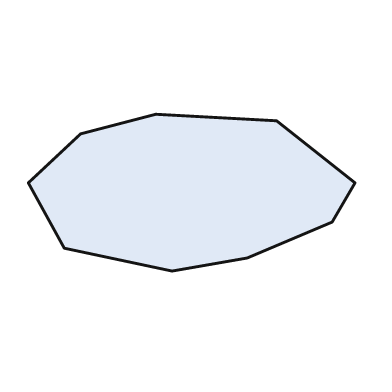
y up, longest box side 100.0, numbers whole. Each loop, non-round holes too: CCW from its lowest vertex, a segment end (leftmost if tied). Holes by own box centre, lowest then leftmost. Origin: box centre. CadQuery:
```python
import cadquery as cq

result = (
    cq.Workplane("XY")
    .moveTo(-6.0, -24.0)
    .lineTo(17.0, -20.0)
    .lineTo(43.0, -9.0)
    .lineTo(50.0, 3.0)
    .lineTo(26.0, 22.0)
    .lineTo(-11.0, 24.0)
    .lineTo(-34.0, 18.0)
    .lineTo(-50.0, 3.0)
    .lineTo(-39.0, -17.0)
    .close()
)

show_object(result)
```